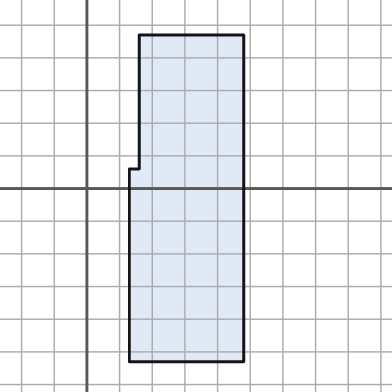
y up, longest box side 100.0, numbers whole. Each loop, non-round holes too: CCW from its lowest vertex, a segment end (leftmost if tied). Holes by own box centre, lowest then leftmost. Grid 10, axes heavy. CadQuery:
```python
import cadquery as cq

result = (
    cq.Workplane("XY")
    .moveTo(13.0, -53.0)
    .lineTo(48.0, -53.0)
    .lineTo(48.0, 47.0)
    .lineTo(16.0, 47.0)
    .lineTo(16.0, 6.0)
    .lineTo(13.0, 6.0)
    .close()
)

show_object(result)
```